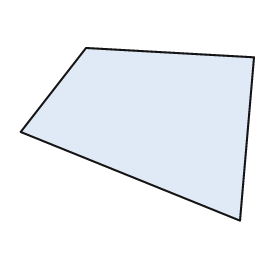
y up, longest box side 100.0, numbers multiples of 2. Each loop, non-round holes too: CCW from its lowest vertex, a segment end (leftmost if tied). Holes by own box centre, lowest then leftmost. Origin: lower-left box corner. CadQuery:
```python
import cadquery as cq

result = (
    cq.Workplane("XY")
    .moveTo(94.0, 0.0)
    .lineTo(100.0, 70.0)
    .lineTo(28.0, 74.0)
    .lineTo(0.0, 38.0)
    .close()
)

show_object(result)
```